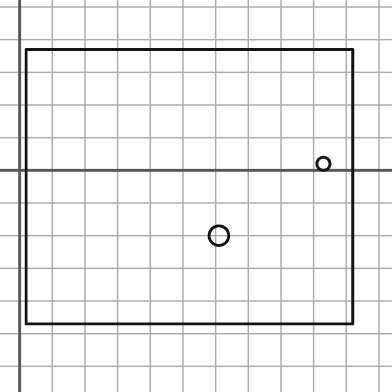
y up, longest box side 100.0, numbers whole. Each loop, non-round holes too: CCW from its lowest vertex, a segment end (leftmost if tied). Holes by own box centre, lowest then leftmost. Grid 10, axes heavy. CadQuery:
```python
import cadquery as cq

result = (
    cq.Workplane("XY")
    .moveTo(2.0, -47.0)
    .lineTo(102.0, -47.0)
    .lineTo(102.0, 37.0)
    .lineTo(2.0, 37.0)
    .close()
    .moveTo(61.0, -20.0)
    .circle(3.0)
    .moveTo(93.0, 2.0)
    .circle(2.0)
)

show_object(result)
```